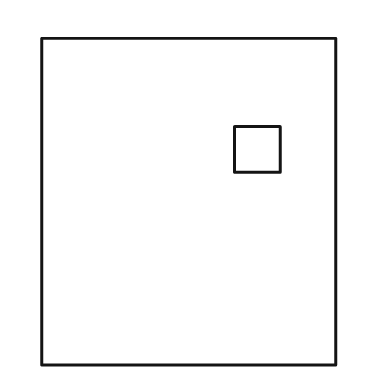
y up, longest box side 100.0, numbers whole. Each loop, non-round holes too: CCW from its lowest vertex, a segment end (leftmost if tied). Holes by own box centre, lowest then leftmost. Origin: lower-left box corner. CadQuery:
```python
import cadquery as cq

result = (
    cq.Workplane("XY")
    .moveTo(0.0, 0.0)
    .lineTo(90.0, 0.0)
    .lineTo(90.0, 100.0)
    .lineTo(0.0, 100.0)
    .close()
    .moveTo(59.0, 59.0)
    .lineTo(73.0, 59.0)
    .lineTo(73.0, 73.0)
    .lineTo(59.0, 73.0)
    .close()
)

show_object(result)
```